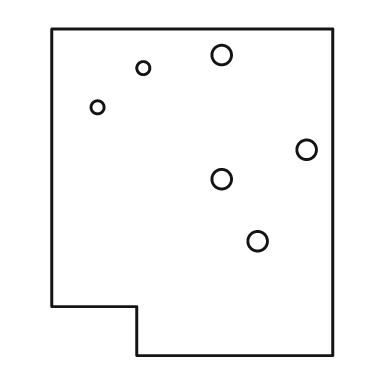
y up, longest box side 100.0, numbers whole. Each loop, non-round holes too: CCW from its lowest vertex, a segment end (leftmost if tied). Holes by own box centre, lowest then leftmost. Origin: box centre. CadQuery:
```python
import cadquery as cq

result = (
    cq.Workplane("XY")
    .moveTo(-17.0, -50.0)
    .lineTo(43.0, -50.0)
    .lineTo(43.0, 50.0)
    .lineTo(-43.0, 50.0)
    .lineTo(-43.0, -35.0)
    .lineTo(-17.0, -35.0)
    .close()
    .moveTo(20.0, -15.0)
    .circle(3.0)
    .moveTo(9.0, 4.0)
    .circle(3.0)
    .moveTo(35.0, 13.0)
    .circle(3.0)
    .moveTo(-29.0, 26.0)
    .circle(2.0)
    .moveTo(-15.0, 38.0)
    .circle(2.0)
    .moveTo(9.0, 42.0)
    .circle(3.0)
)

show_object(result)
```